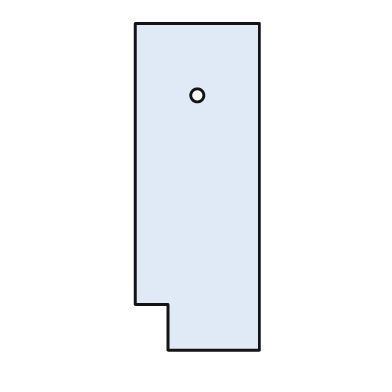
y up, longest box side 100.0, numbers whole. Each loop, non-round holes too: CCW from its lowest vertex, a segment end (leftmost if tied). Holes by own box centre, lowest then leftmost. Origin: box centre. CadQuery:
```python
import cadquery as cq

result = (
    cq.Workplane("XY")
    .moveTo(-9.0, -50.0)
    .lineTo(19.0, -50.0)
    .lineTo(19.0, 50.0)
    .lineTo(-19.0, 50.0)
    .lineTo(-19.0, -36.0)
    .lineTo(-9.0, -36.0)
    .close()
    .moveTo(0.0, 28.0)
    .circle(2.0)
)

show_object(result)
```